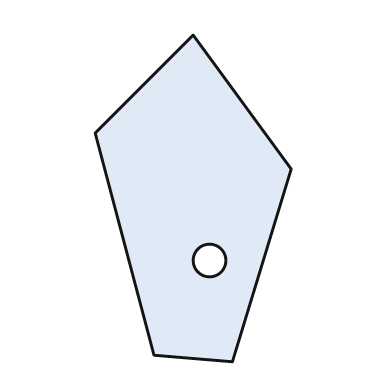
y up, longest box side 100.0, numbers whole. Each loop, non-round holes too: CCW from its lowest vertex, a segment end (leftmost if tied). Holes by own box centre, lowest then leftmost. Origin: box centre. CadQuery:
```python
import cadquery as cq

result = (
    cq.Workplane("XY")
    .moveTo(12.0, -50.0)
    .lineTo(30.0, 9.0)
    .lineTo(0.0, 50.0)
    .lineTo(-30.0, 20.0)
    .lineTo(-12.0, -48.0)
    .close()
    .moveTo(5.0, -19.0)
    .circle(5.0)
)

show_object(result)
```